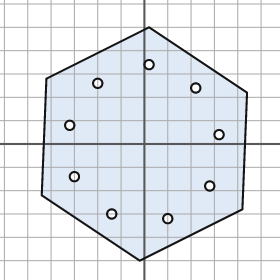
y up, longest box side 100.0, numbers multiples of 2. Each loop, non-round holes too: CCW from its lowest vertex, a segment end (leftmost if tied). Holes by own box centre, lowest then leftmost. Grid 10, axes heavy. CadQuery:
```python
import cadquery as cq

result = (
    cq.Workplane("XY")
    .moveTo(-2.0, -50.0)
    .lineTo(42.0, -28.0)
    .lineTo(44.0, 22.0)
    .lineTo(2.0, 50.0)
    .lineTo(-42.0, 28.0)
    .lineTo(-44.0, -22.0)
    .close()
    .moveTo(10.0, -32.0)
    .circle(2.0)
    .moveTo(-14.0, -30.0)
    .circle(2.0)
    .moveTo(28.0, -18.0)
    .circle(2.0)
    .moveTo(-30.0, -14.0)
    .circle(2.0)
    .moveTo(32.0, 4.0)
    .circle(2.0)
    .moveTo(-32.0, 8.0)
    .circle(2.0)
    .moveTo(22.0, 24.0)
    .circle(2.0)
    .moveTo(-20.0, 26.0)
    .circle(2.0)
    .moveTo(2.0, 34.0)
    .circle(2.0)
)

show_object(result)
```